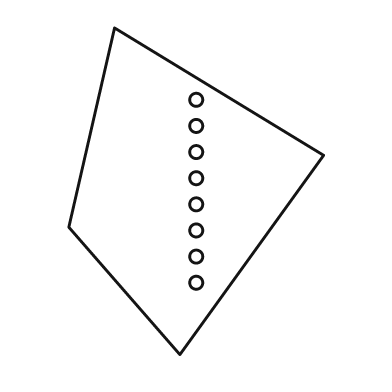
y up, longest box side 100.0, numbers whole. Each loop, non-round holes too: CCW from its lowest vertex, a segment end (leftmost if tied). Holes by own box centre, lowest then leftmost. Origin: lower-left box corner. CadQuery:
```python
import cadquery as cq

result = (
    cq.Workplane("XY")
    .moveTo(34.0, 0.0)
    .lineTo(78.0, 61.0)
    .lineTo(14.0, 100.0)
    .lineTo(0.0, 39.0)
    .close()
    .moveTo(39.0, 22.0)
    .circle(2.0)
    .moveTo(39.0, 30.0)
    .circle(2.0)
    .moveTo(39.0, 38.0)
    .circle(2.0)
    .moveTo(39.0, 46.0)
    .circle(2.0)
    .moveTo(39.0, 54.0)
    .circle(2.0)
    .moveTo(39.0, 62.0)
    .circle(2.0)
    .moveTo(39.0, 70.0)
    .circle(2.0)
    .moveTo(39.0, 78.0)
    .circle(2.0)
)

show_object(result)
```